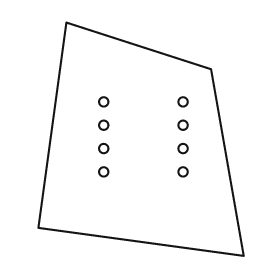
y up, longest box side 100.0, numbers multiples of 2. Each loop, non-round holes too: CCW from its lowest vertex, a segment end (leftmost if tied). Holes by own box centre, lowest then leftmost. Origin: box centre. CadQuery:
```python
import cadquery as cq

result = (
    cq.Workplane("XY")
    .moveTo(44.0, -50.0)
    .lineTo(30.0, 30.0)
    .lineTo(-32.0, 50.0)
    .lineTo(-44.0, -38.0)
    .close()
    .moveTo(-16.0, -14.0)
    .circle(2.0)
    .moveTo(18.0, -14.0)
    .circle(2.0)
    .moveTo(-16.0, -4.0)
    .circle(2.0)
    .moveTo(18.0, -4.0)
    .circle(2.0)
    .moveTo(-16.0, 6.0)
    .circle(2.0)
    .moveTo(18.0, 6.0)
    .circle(2.0)
    .moveTo(-16.0, 16.0)
    .circle(2.0)
    .moveTo(18.0, 16.0)
    .circle(2.0)
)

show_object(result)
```